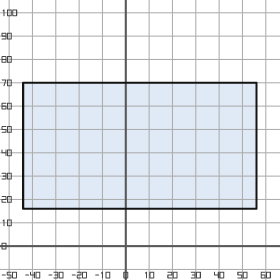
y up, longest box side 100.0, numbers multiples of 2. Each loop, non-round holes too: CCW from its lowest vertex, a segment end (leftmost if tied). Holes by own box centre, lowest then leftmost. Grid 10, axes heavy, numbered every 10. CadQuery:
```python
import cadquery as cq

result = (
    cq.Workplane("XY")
    .moveTo(-44.0, 16.0)
    .lineTo(56.0, 16.0)
    .lineTo(56.0, 70.0)
    .lineTo(-44.0, 70.0)
    .close()
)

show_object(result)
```